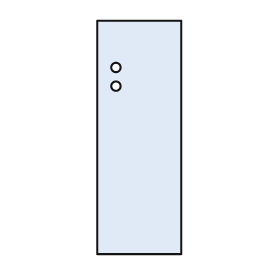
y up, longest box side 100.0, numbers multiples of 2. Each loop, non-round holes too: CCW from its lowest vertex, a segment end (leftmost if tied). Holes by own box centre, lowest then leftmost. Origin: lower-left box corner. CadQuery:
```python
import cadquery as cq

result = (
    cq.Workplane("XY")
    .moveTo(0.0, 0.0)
    .lineTo(36.0, 0.0)
    .lineTo(36.0, 100.0)
    .lineTo(0.0, 100.0)
    .close()
    .moveTo(8.0, 72.0)
    .circle(2.0)
    .moveTo(8.0, 80.0)
    .circle(2.0)
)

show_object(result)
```